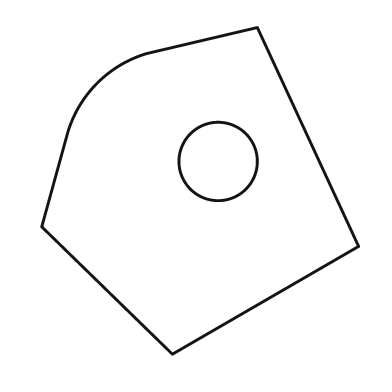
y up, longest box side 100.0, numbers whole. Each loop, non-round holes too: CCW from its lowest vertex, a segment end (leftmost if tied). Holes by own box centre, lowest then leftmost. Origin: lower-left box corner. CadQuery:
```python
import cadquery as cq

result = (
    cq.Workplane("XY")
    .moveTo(40.0, 0.0)
    .lineTo(97.0, 33.0)
    .lineTo(66.0, 100.0)
    .lineTo(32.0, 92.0)
    .threePointArc((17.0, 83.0), (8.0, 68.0))
    .lineTo(0.0, 39.0)
    .close()
    .moveTo(54.0, 59.0)
    .circle(12.0)
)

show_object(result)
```